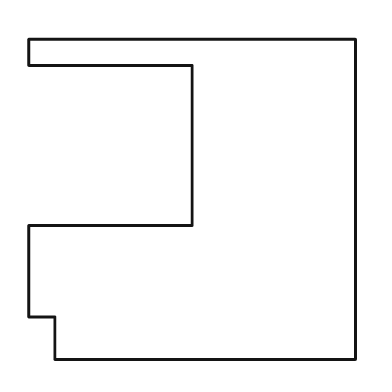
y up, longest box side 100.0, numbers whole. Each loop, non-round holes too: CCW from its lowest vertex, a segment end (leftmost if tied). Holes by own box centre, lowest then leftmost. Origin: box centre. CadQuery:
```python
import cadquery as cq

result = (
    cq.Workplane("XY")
    .moveTo(-42.0, -49.0)
    .lineTo(50.0, -49.0)
    .lineTo(50.0, 49.0)
    .lineTo(-50.0, 49.0)
    .lineTo(-50.0, 41.0)
    .lineTo(0.0, 41.0)
    .lineTo(0.0, -8.0)
    .lineTo(-50.0, -8.0)
    .lineTo(-50.0, -36.0)
    .lineTo(-42.0, -36.0)
    .close()
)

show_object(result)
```